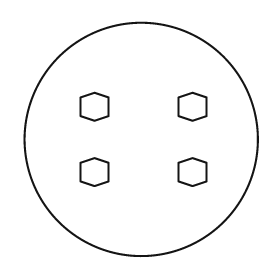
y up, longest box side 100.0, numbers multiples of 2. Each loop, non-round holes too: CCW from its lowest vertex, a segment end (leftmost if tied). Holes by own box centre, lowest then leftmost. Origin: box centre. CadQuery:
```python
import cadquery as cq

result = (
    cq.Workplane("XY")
    .moveTo(0.0, 0.0)
    .circle(50.0)
    .moveTo(-20.0, -20.0)
    .lineTo(-14.0, -18.0)
    .lineTo(-14.0, -10.0)
    .lineTo(-20.0, -8.0)
    .lineTo(-26.0, -10.0)
    .lineTo(-26.0, -18.0)
    .close()
    .moveTo(22.0, -20.0)
    .lineTo(28.0, -18.0)
    .lineTo(28.0, -10.0)
    .lineTo(22.0, -8.0)
    .lineTo(16.0, -10.0)
    .lineTo(16.0, -18.0)
    .close()
    .moveTo(-20.0, 8.0)
    .lineTo(-14.0, 10.0)
    .lineTo(-14.0, 18.0)
    .lineTo(-20.0, 20.0)
    .lineTo(-26.0, 18.0)
    .lineTo(-26.0, 10.0)
    .close()
    .moveTo(22.0, 8.0)
    .lineTo(28.0, 10.0)
    .lineTo(28.0, 18.0)
    .lineTo(22.0, 20.0)
    .lineTo(16.0, 18.0)
    .lineTo(16.0, 10.0)
    .close()
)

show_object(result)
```